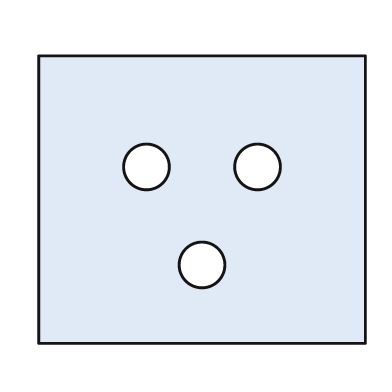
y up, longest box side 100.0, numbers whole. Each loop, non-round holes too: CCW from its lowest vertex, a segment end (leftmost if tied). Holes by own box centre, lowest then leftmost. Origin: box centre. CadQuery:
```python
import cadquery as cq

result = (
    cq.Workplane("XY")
    .moveTo(-50.0, -44.0)
    .lineTo(50.0, -44.0)
    .lineTo(50.0, 44.0)
    .lineTo(-50.0, 44.0)
    .close()
    .moveTo(0.0, -20.0)
    .circle(7.0)
    .moveTo(-17.0, 10.0)
    .circle(7.0)
    .moveTo(17.0, 10.0)
    .circle(7.0)
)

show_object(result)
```